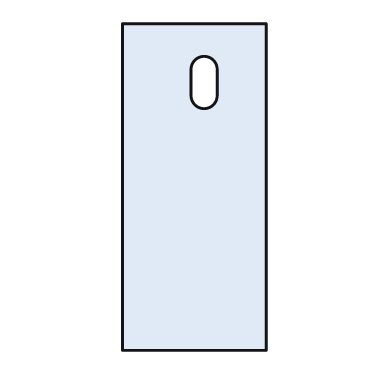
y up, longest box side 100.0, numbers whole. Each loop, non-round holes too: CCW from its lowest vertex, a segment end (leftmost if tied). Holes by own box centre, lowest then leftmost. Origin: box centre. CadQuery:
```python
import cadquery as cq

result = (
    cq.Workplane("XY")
    .moveTo(-22.0, -50.0)
    .lineTo(22.0, -50.0)
    .lineTo(22.0, 50.0)
    .lineTo(-22.0, 50.0)
    .close()
    .moveTo(-1.0, 28.0)
    .threePointArc((3.0, 24.0), (7.0, 28.0))
    .lineTo(7.0, 36.0)
    .threePointArc((3.0, 40.0), (-1.0, 36.0))
    .close()
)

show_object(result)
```